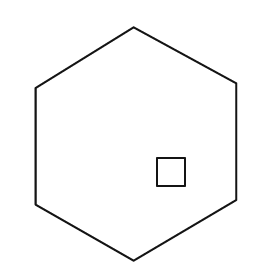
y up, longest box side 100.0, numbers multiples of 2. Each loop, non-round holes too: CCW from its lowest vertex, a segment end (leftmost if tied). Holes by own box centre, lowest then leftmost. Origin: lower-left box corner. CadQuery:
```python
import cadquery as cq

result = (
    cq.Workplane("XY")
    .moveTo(42.0, 0.0)
    .lineTo(86.0, 26.0)
    .lineTo(86.0, 76.0)
    .lineTo(42.0, 100.0)
    .lineTo(0.0, 74.0)
    .lineTo(0.0, 24.0)
    .close()
    .moveTo(52.0, 32.0)
    .lineTo(64.0, 32.0)
    .lineTo(64.0, 44.0)
    .lineTo(52.0, 44.0)
    .close()
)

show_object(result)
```